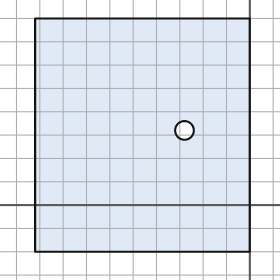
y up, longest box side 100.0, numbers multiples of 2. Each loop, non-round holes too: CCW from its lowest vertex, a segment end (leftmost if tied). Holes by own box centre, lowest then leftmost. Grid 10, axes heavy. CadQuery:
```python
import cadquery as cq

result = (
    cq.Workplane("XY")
    .moveTo(-92.0, -20.0)
    .lineTo(0.0, -20.0)
    .lineTo(0.0, 80.0)
    .lineTo(-92.0, 80.0)
    .close()
    .moveTo(-28.0, 32.0)
    .circle(4.0)
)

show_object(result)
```